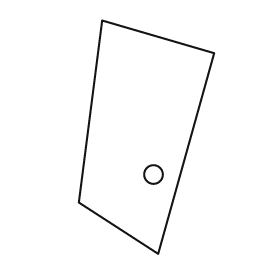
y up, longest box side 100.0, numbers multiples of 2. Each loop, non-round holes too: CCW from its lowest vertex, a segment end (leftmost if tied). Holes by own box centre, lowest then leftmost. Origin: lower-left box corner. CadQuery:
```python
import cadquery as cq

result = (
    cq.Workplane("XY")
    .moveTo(34.0, 0.0)
    .lineTo(58.0, 86.0)
    .lineTo(10.0, 100.0)
    .lineTo(0.0, 22.0)
    .close()
    .moveTo(32.0, 34.0)
    .circle(4.0)
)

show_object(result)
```